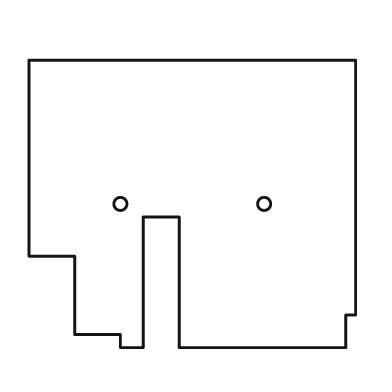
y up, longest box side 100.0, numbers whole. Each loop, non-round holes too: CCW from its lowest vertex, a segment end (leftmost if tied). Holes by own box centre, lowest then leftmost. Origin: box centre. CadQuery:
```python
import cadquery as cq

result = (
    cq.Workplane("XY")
    .moveTo(-22.0, -44.0)
    .lineTo(-15.0, -44.0)
    .lineTo(-15.0, -4.0)
    .lineTo(-4.0, -4.0)
    .lineTo(-4.0, -44.0)
    .lineTo(47.0, -44.0)
    .lineTo(47.0, -34.0)
    .lineTo(50.0, -34.0)
    .lineTo(50.0, 44.0)
    .lineTo(-50.0, 44.0)
    .lineTo(-50.0, -16.0)
    .lineTo(-36.0, -16.0)
    .lineTo(-36.0, -40.0)
    .lineTo(-22.0, -40.0)
    .close()
    .moveTo(-22.0, 0.0)
    .circle(2.0)
    .moveTo(22.0, 0.0)
    .circle(2.0)
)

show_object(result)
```